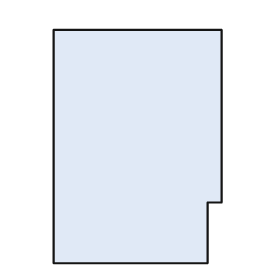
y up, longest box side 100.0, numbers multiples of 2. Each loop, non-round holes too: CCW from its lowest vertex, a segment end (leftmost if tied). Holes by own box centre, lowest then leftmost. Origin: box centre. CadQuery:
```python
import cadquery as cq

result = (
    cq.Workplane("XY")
    .moveTo(-36.0, -50.0)
    .lineTo(30.0, -50.0)
    .lineTo(30.0, -24.0)
    .lineTo(36.0, -24.0)
    .lineTo(36.0, 50.0)
    .lineTo(-36.0, 50.0)
    .close()
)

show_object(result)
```